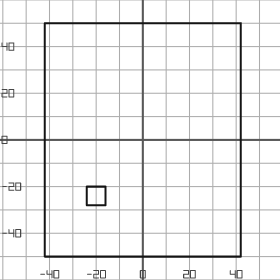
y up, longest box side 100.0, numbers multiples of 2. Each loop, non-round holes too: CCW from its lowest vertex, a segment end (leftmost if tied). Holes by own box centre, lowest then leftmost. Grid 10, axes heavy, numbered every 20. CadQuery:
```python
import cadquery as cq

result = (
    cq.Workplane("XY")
    .moveTo(-42.0, -50.0)
    .lineTo(42.0, -50.0)
    .lineTo(42.0, 50.0)
    .lineTo(-42.0, 50.0)
    .close()
    .moveTo(-24.0, -28.0)
    .lineTo(-16.0, -28.0)
    .lineTo(-16.0, -20.0)
    .lineTo(-24.0, -20.0)
    .close()
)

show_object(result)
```